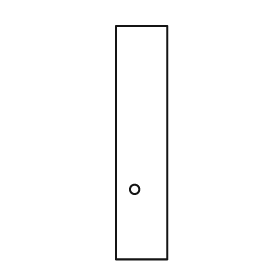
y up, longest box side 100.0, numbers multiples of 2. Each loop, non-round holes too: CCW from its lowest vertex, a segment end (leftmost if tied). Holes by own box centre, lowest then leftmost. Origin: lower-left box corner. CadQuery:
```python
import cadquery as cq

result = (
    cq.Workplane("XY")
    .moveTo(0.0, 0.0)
    .lineTo(22.0, 0.0)
    .lineTo(22.0, 100.0)
    .lineTo(0.0, 100.0)
    .close()
    .moveTo(8.0, 30.0)
    .circle(2.0)
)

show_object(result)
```